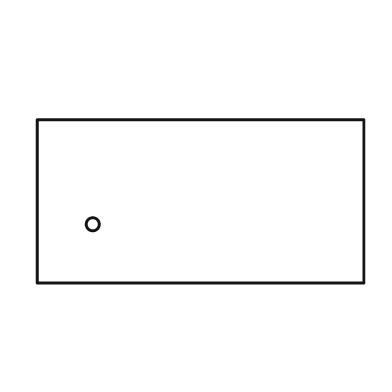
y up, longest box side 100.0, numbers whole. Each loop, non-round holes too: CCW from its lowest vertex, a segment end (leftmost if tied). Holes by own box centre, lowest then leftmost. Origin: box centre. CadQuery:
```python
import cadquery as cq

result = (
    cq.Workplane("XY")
    .moveTo(-50.0, -25.0)
    .lineTo(50.0, -25.0)
    .lineTo(50.0, 25.0)
    .lineTo(-50.0, 25.0)
    .close()
    .moveTo(-33.0, -7.0)
    .circle(2.0)
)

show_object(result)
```